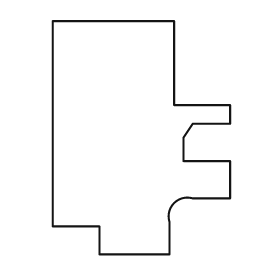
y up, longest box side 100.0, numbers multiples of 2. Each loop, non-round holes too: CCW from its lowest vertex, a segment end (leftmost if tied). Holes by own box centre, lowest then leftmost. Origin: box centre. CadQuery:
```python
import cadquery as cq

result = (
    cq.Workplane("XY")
    .moveTo(-18.0, -50.0)
    .lineTo(12.0, -50.0)
    .lineTo(12.0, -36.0)
    .threePointArc((14.0, -28.0), (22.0, -26.0))
    .lineTo(38.0, -26.0)
    .lineTo(38.0, -10.0)
    .lineTo(18.0, -10.0)
    .lineTo(18.0, 0.0)
    .lineTo(22.0, 6.0)
    .lineTo(38.0, 6.0)
    .lineTo(38.0, 14.0)
    .lineTo(14.0, 14.0)
    .lineTo(14.0, 50.0)
    .lineTo(-38.0, 50.0)
    .lineTo(-38.0, -38.0)
    .lineTo(-18.0, -38.0)
    .close()
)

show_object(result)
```